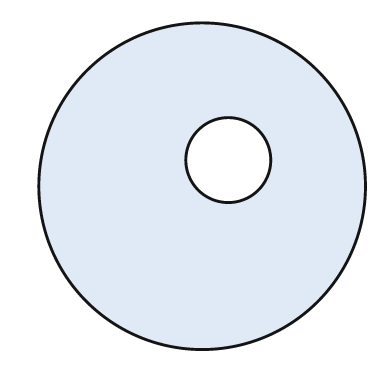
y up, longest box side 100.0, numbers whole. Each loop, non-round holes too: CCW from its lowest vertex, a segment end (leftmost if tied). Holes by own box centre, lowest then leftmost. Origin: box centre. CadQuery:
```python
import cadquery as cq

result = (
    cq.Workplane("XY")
    .moveTo(0.0, 0.0)
    .circle(50.0)
    .moveTo(8.0, 8.0)
    .circle(13.0)
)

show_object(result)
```